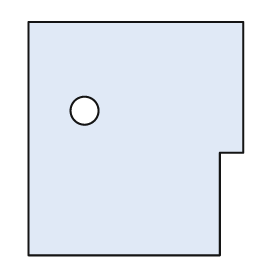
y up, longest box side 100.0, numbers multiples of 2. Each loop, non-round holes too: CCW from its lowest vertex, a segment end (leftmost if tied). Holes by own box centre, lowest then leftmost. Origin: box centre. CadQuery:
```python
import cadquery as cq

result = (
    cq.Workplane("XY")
    .moveTo(-46.0, -50.0)
    .lineTo(36.0, -50.0)
    .lineTo(36.0, -6.0)
    .lineTo(46.0, -6.0)
    .lineTo(46.0, 50.0)
    .lineTo(-46.0, 50.0)
    .close()
    .moveTo(-22.0, 12.0)
    .circle(6.0)
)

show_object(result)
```